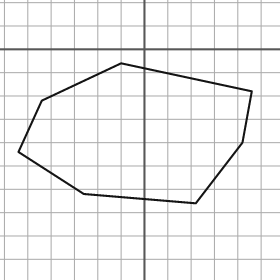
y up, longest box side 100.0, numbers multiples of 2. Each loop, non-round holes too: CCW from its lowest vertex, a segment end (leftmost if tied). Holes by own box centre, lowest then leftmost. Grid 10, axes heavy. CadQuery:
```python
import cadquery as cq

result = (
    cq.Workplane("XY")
    .moveTo(22.0, -66.0)
    .lineTo(42.0, -40.0)
    .lineTo(46.0, -18.0)
    .lineTo(-10.0, -6.0)
    .lineTo(-44.0, -22.0)
    .lineTo(-54.0, -44.0)
    .lineTo(-26.0, -62.0)
    .close()
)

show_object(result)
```